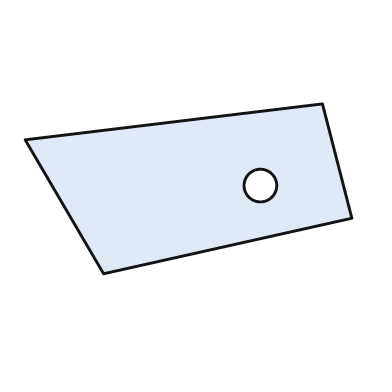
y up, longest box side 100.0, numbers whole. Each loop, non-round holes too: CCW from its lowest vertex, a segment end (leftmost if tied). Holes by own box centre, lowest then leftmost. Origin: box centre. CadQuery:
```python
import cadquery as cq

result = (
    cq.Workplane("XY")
    .moveTo(-26.0, -26.0)
    .lineTo(50.0, -9.0)
    .lineTo(41.0, 26.0)
    .lineTo(-50.0, 15.0)
    .close()
    .moveTo(22.0, 1.0)
    .circle(5.0)
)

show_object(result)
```